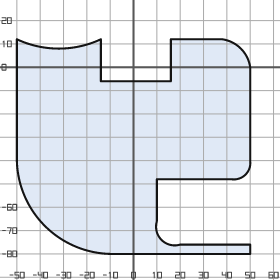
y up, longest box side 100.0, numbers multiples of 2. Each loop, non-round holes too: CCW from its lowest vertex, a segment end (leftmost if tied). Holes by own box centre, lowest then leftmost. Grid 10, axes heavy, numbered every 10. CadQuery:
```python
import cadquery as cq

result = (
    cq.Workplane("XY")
    .moveTo(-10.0, -80.0)
    .lineTo(50.0, -80.0)
    .lineTo(50.0, -76.0)
    .lineTo(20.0, -76.0)
    .threePointArc((12.0, -74.0), (10.0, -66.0))
    .lineTo(10.0, -48.0)
    .lineTo(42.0, -48.0)
    .threePointArc((48.0, -46.0), (50.0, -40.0))
    .lineTo(50.0, 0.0)
    .threePointArc((46.0, 8.0), (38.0, 12.0))
    .lineTo(16.0, 12.0)
    .lineTo(16.0, -6.0)
    .lineTo(-14.0, -6.0)
    .lineTo(-14.0, 12.0)
    .threePointArc((-32.0, 8.0), (-50.0, 12.0))
    .lineTo(-50.0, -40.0)
    .threePointArc((-38.0, -68.0), (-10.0, -80.0))
    .close()
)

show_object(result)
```